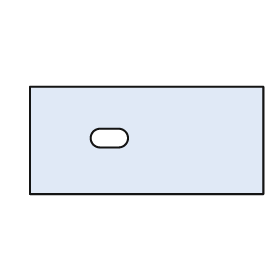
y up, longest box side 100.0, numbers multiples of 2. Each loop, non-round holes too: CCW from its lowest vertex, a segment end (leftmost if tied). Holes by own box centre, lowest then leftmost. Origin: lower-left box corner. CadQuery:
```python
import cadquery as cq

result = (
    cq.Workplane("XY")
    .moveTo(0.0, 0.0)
    .lineTo(100.0, 0.0)
    .lineTo(100.0, 46.0)
    .lineTo(0.0, 46.0)
    .close()
    .moveTo(30.0, 20.0)
    .lineTo(38.0, 20.0)
    .threePointArc((42.0, 24.0), (38.0, 28.0))
    .lineTo(30.0, 28.0)
    .threePointArc((26.0, 24.0), (30.0, 20.0))
    .close()
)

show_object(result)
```